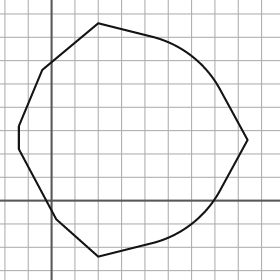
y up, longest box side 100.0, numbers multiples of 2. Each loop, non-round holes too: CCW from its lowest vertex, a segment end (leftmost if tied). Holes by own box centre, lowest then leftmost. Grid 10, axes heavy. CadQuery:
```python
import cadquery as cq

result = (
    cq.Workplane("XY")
    .moveTo(20.0, -24.0)
    .lineTo(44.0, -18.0)
    .threePointArc((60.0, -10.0), (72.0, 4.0))
    .lineTo(84.0, 26.0)
    .lineTo(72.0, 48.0)
    .threePointArc((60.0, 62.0), (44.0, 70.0))
    .lineTo(20.0, 76.0)
    .lineTo(-4.0, 56.0)
    .lineTo(-14.0, 32.0)
    .lineTo(-14.0, 22.0)
    .lineTo(2.0, -8.0)
    .close()
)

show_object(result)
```